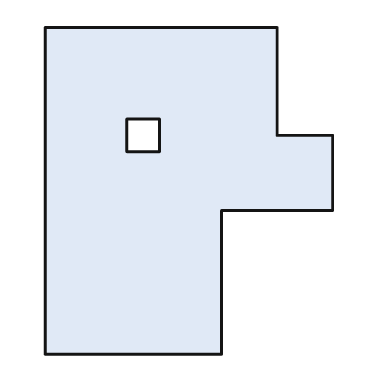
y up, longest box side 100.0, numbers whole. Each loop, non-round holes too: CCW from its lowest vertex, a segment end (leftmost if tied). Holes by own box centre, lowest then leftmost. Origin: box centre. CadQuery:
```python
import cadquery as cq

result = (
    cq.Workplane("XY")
    .moveTo(-44.0, -50.0)
    .lineTo(10.0, -50.0)
    .lineTo(10.0, -6.0)
    .lineTo(44.0, -6.0)
    .lineTo(44.0, 17.0)
    .lineTo(27.0, 17.0)
    .lineTo(27.0, 50.0)
    .lineTo(-44.0, 50.0)
    .close()
    .moveTo(-19.0, 12.0)
    .lineTo(-9.0, 12.0)
    .lineTo(-9.0, 22.0)
    .lineTo(-19.0, 22.0)
    .close()
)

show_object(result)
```